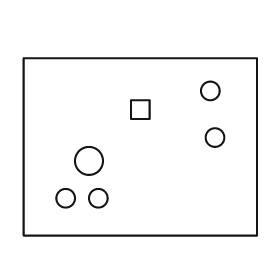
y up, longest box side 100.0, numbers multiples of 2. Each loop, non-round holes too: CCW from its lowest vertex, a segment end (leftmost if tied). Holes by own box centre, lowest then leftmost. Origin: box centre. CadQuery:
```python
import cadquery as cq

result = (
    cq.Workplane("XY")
    .moveTo(-50.0, -38.0)
    .lineTo(50.0, -38.0)
    .lineTo(50.0, 38.0)
    .lineTo(-50.0, 38.0)
    .close()
    .moveTo(-32.0, -22.0)
    .circle(4.0)
    .moveTo(-18.0, -22.0)
    .circle(4.0)
    .moveTo(-22.0, -6.0)
    .circle(6.0)
    .moveTo(32.0, 4.0)
    .circle(4.0)
    .moveTo(-4.0, 12.0)
    .lineTo(4.0, 12.0)
    .lineTo(4.0, 20.0)
    .lineTo(-4.0, 20.0)
    .close()
    .moveTo(30.0, 24.0)
    .circle(4.0)
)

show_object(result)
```